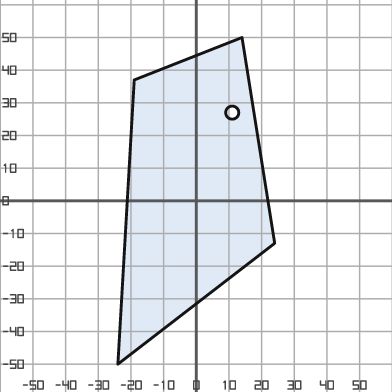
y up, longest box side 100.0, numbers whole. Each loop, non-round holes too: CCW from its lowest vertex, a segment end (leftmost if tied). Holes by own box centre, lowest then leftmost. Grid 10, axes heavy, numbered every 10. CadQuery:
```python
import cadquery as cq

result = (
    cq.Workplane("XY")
    .moveTo(-24.0, -50.0)
    .lineTo(24.0, -13.0)
    .lineTo(14.0, 50.0)
    .lineTo(-19.0, 37.0)
    .close()
    .moveTo(11.0, 27.0)
    .circle(2.0)
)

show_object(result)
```